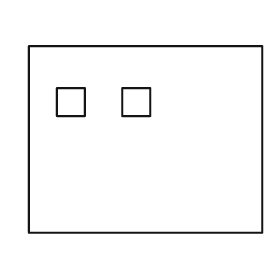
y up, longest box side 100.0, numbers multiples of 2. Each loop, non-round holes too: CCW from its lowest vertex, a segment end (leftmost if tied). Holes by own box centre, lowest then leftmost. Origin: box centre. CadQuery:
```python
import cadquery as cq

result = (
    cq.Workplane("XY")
    .moveTo(-50.0, -40.0)
    .lineTo(50.0, -40.0)
    .lineTo(50.0, 40.0)
    .lineTo(-50.0, 40.0)
    .close()
    .moveTo(-38.0, 10.0)
    .lineTo(-26.0, 10.0)
    .lineTo(-26.0, 22.0)
    .lineTo(-38.0, 22.0)
    .close()
    .moveTo(-10.0, 10.0)
    .lineTo(2.0, 10.0)
    .lineTo(2.0, 22.0)
    .lineTo(-10.0, 22.0)
    .close()
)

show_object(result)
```